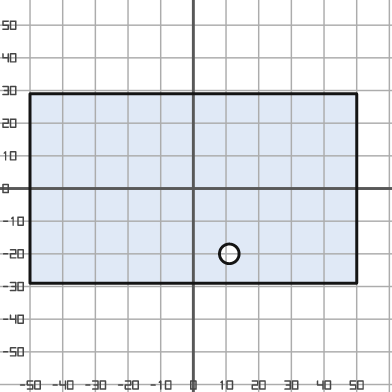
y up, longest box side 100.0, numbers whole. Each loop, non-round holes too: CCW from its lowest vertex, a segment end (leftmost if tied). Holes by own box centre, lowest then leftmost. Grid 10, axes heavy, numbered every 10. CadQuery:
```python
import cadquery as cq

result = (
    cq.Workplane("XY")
    .moveTo(-50.0, -29.0)
    .lineTo(50.0, -29.0)
    .lineTo(50.0, 29.0)
    .lineTo(-50.0, 29.0)
    .close()
    .moveTo(11.0, -20.0)
    .circle(3.0)
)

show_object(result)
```